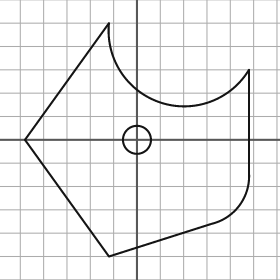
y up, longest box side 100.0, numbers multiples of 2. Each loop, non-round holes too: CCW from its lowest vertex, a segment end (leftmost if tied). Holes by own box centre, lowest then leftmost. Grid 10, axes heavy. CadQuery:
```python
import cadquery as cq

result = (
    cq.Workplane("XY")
    .moveTo(-12.0, -50.0)
    .lineTo(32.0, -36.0)
    .threePointArc((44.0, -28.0), (48.0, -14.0))
    .lineTo(48.0, 30.0)
    .threePointArc((10.0, 16.0), (-12.0, 50.0))
    .lineTo(-48.0, 0.0)
    .close()
    .moveTo(0.0, 0.0)
    .circle(6.0)
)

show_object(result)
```